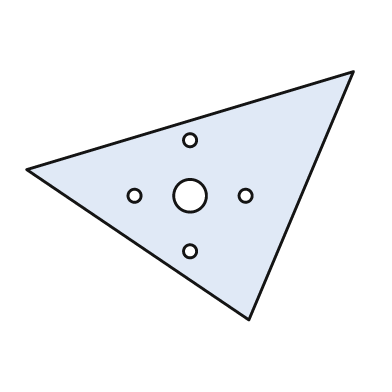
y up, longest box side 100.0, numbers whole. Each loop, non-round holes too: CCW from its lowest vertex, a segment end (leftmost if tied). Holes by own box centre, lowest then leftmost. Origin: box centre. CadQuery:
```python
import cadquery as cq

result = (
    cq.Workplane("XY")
    .moveTo(18.0, -38.0)
    .lineTo(50.0, 38.0)
    .lineTo(-50.0, 8.0)
    .close()
    .moveTo(0.0, -17.0)
    .circle(2.0)
    .moveTo(-17.0, 0.0)
    .circle(2.0)
    .moveTo(0.0, 0.0)
    .circle(5.0)
    .moveTo(17.0, 0.0)
    .circle(2.0)
    .moveTo(0.0, 17.0)
    .circle(2.0)
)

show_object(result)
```